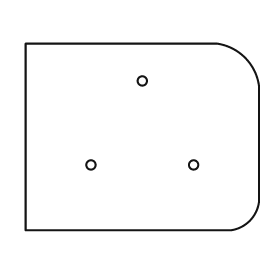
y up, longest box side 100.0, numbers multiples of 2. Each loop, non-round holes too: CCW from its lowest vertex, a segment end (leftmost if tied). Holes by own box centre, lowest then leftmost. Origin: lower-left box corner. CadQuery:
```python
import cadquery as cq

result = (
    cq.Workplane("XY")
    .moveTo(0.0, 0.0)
    .lineTo(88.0, 0.0)
    .threePointArc((96.0, 4.0), (100.0, 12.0))
    .lineTo(100.0, 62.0)
    .threePointArc((94.0, 74.0), (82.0, 80.0))
    .lineTo(0.0, 80.0)
    .close()
    .moveTo(28.0, 28.0)
    .circle(2.0)
    .moveTo(72.0, 28.0)
    .circle(2.0)
    .moveTo(50.0, 64.0)
    .circle(2.0)
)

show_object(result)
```